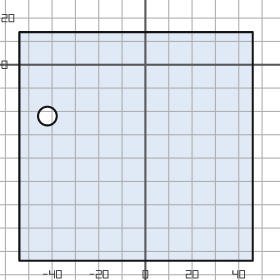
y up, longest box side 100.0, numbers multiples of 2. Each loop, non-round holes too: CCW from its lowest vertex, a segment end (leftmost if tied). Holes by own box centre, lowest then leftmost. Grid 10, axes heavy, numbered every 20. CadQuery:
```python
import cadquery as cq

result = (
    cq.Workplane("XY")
    .moveTo(-54.0, -84.0)
    .lineTo(46.0, -84.0)
    .lineTo(46.0, 14.0)
    .lineTo(-54.0, 14.0)
    .close()
    .moveTo(-42.0, -22.0)
    .circle(4.0)
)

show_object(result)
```